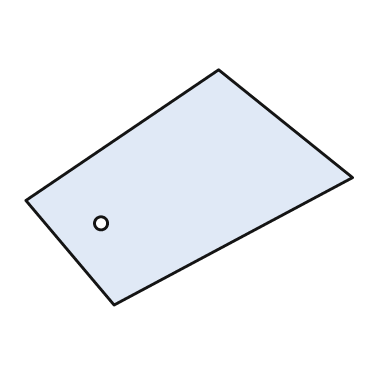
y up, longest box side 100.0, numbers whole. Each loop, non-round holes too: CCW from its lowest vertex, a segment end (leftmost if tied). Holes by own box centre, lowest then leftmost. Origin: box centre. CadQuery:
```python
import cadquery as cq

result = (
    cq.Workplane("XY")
    .moveTo(-23.0, -36.0)
    .lineTo(50.0, 3.0)
    .lineTo(9.0, 36.0)
    .lineTo(-50.0, -4.0)
    .close()
    .moveTo(-27.0, -11.0)
    .circle(2.0)
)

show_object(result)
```